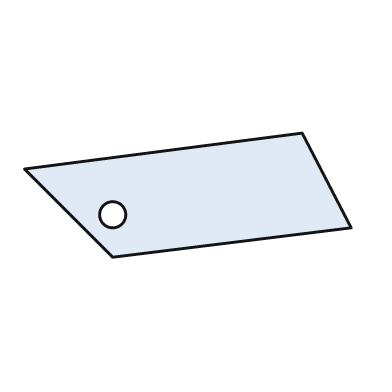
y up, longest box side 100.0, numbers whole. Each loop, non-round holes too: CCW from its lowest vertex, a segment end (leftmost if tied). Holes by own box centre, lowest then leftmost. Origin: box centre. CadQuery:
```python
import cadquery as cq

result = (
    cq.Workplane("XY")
    .moveTo(-23.0, -19.0)
    .lineTo(50.0, -10.0)
    .lineTo(35.0, 19.0)
    .lineTo(-50.0, 8.0)
    .close()
    .moveTo(-23.0, -6.0)
    .circle(4.0)
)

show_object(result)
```